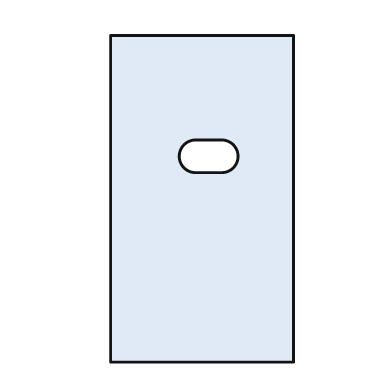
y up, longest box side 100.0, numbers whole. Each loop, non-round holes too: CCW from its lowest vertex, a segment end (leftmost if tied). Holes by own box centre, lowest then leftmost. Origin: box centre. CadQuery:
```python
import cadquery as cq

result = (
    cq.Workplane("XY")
    .moveTo(-28.0, -50.0)
    .lineTo(28.0, -50.0)
    .lineTo(28.0, 50.0)
    .lineTo(-28.0, 50.0)
    .close()
    .moveTo(-2.0, 8.0)
    .lineTo(6.0, 8.0)
    .threePointArc((11.0, 13.0), (6.0, 18.0))
    .lineTo(-2.0, 18.0)
    .threePointArc((-7.0, 13.0), (-2.0, 8.0))
    .close()
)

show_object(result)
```